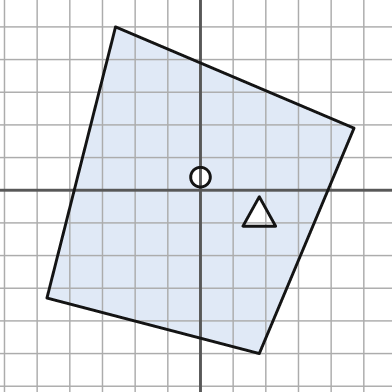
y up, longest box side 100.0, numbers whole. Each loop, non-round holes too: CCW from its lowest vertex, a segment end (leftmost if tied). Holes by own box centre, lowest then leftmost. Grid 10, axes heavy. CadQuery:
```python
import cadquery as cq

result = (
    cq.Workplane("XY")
    .moveTo(18.0, -50.0)
    .lineTo(47.0, 19.0)
    .lineTo(-26.0, 50.0)
    .lineTo(-47.0, -33.0)
    .close()
    .moveTo(13.0, -11.0)
    .lineTo(23.0, -11.0)
    .lineTo(18.0, -2.0)
    .close()
    .moveTo(0.0, 4.0)
    .circle(3.0)
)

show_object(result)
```